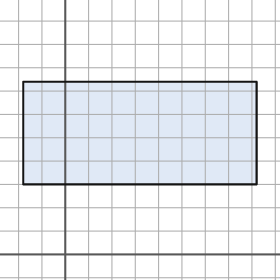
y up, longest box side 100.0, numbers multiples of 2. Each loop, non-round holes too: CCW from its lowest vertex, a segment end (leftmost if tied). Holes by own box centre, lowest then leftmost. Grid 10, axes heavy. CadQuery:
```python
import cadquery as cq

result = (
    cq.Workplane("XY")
    .moveTo(-18.0, 30.0)
    .lineTo(82.0, 30.0)
    .lineTo(82.0, 74.0)
    .lineTo(-18.0, 74.0)
    .close()
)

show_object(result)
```